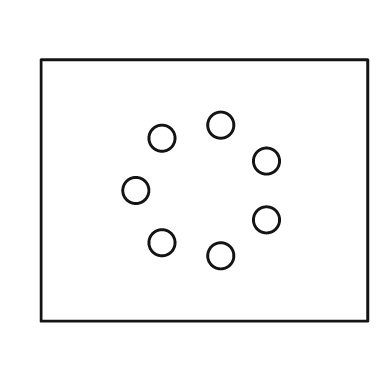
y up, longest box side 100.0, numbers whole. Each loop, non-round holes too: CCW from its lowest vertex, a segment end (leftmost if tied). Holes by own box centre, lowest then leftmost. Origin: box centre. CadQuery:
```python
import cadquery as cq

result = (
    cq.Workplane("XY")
    .moveTo(-50.0, -40.0)
    .lineTo(50.0, -40.0)
    .lineTo(50.0, 40.0)
    .lineTo(-50.0, 40.0)
    .close()
    .moveTo(5.0, -20.0)
    .circle(4.0)
    .moveTo(-13.0, -16.0)
    .circle(4.0)
    .moveTo(19.0, -9.0)
    .circle(4.0)
    .moveTo(-21.0, 0.0)
    .circle(4.0)
    .moveTo(19.0, 9.0)
    .circle(4.0)
    .moveTo(-13.0, 16.0)
    .circle(4.0)
    .moveTo(5.0, 20.0)
    .circle(4.0)
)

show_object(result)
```